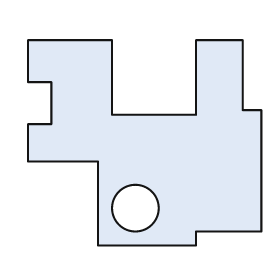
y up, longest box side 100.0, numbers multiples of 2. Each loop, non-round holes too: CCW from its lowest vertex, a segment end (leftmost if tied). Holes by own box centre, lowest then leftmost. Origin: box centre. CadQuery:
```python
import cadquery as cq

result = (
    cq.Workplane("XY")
    .moveTo(-20.0, -44.0)
    .lineTo(22.0, -44.0)
    .lineTo(22.0, -38.0)
    .lineTo(50.0, -38.0)
    .lineTo(50.0, 14.0)
    .lineTo(42.0, 14.0)
    .lineTo(42.0, 44.0)
    .lineTo(22.0, 44.0)
    .lineTo(22.0, 12.0)
    .lineTo(-14.0, 12.0)
    .lineTo(-14.0, 44.0)
    .lineTo(-50.0, 44.0)
    .lineTo(-50.0, 26.0)
    .lineTo(-40.0, 26.0)
    .lineTo(-40.0, 8.0)
    .lineTo(-50.0, 8.0)
    .lineTo(-50.0, -8.0)
    .lineTo(-20.0, -8.0)
    .close()
    .moveTo(-4.0, -28.0)
    .circle(10.0)
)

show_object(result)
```